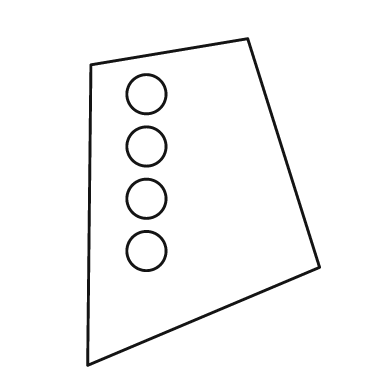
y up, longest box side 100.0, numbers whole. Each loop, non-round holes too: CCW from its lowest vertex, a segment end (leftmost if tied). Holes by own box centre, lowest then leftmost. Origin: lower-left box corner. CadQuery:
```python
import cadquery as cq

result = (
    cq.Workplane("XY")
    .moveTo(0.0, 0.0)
    .lineTo(71.0, 30.0)
    .lineTo(49.0, 100.0)
    .lineTo(1.0, 92.0)
    .close()
    .moveTo(18.0, 35.0)
    .circle(6.0)
    .moveTo(18.0, 51.0)
    .circle(6.0)
    .moveTo(18.0, 67.0)
    .circle(6.0)
    .moveTo(18.0, 83.0)
    .circle(6.0)
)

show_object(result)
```